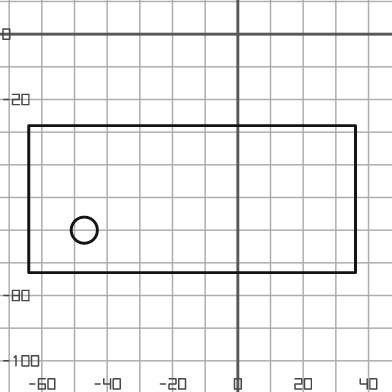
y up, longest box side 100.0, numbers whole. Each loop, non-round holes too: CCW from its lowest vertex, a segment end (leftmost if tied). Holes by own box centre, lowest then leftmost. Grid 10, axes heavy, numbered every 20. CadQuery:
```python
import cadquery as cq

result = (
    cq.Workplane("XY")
    .moveTo(-64.0, -73.0)
    .lineTo(36.0, -73.0)
    .lineTo(36.0, -28.0)
    .lineTo(-64.0, -28.0)
    .close()
    .moveTo(-47.0, -60.0)
    .circle(4.0)
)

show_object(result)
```